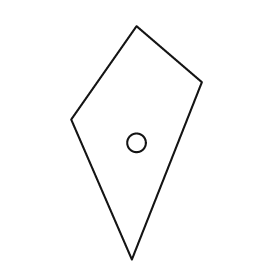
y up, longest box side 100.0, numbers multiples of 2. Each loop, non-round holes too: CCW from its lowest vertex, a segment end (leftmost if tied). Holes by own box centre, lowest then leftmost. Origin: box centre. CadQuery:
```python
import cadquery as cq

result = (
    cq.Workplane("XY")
    .moveTo(-2.0, -50.0)
    .lineTo(28.0, 26.0)
    .lineTo(0.0, 50.0)
    .lineTo(-28.0, 10.0)
    .close()
    .moveTo(0.0, 0.0)
    .circle(4.0)
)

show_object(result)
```